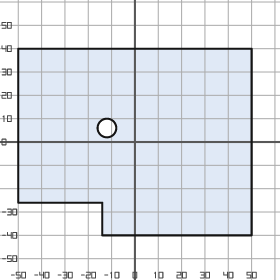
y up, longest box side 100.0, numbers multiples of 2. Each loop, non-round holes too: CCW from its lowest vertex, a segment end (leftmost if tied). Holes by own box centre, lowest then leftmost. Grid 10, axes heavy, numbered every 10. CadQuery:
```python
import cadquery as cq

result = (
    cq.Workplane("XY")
    .moveTo(-14.0, -40.0)
    .lineTo(50.0, -40.0)
    .lineTo(50.0, 40.0)
    .lineTo(-50.0, 40.0)
    .lineTo(-50.0, -26.0)
    .lineTo(-14.0, -26.0)
    .close()
    .moveTo(-12.0, 6.0)
    .circle(4.0)
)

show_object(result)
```